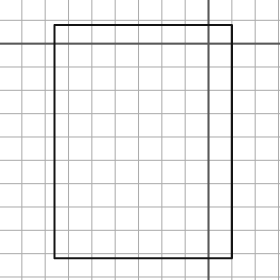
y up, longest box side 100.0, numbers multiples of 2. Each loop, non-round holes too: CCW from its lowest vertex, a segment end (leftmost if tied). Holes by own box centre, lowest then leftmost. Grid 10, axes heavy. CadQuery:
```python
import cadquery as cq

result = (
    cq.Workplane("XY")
    .moveTo(-66.0, -92.0)
    .lineTo(10.0, -92.0)
    .lineTo(10.0, 8.0)
    .lineTo(-66.0, 8.0)
    .close()
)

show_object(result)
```